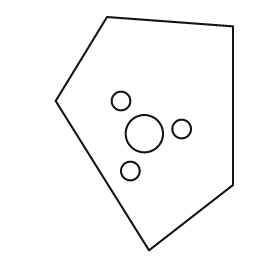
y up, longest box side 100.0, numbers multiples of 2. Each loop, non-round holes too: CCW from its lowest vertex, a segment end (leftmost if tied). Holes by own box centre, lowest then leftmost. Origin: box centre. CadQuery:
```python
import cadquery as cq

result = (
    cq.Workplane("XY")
    .moveTo(2.0, -50.0)
    .lineTo(38.0, -22.0)
    .lineTo(38.0, 46.0)
    .lineTo(-16.0, 50.0)
    .lineTo(-38.0, 14.0)
    .close()
    .moveTo(-6.0, -16.0)
    .circle(4.0)
    .moveTo(0.0, 0.0)
    .circle(8.0)
    .moveTo(16.0, 2.0)
    .circle(4.0)
    .moveTo(-10.0, 14.0)
    .circle(4.0)
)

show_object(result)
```